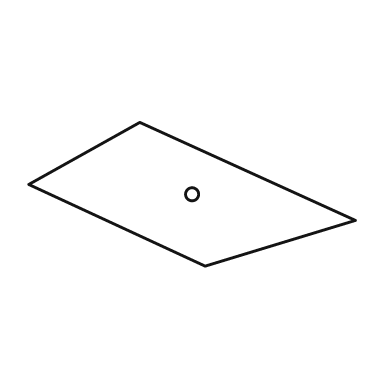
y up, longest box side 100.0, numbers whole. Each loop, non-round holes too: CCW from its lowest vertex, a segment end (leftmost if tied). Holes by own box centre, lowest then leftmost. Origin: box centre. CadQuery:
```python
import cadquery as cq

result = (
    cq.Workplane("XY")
    .moveTo(4.0, -22.0)
    .lineTo(50.0, -8.0)
    .lineTo(-16.0, 22.0)
    .lineTo(-50.0, 3.0)
    .close()
    .moveTo(0.0, 0.0)
    .circle(2.0)
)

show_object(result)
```